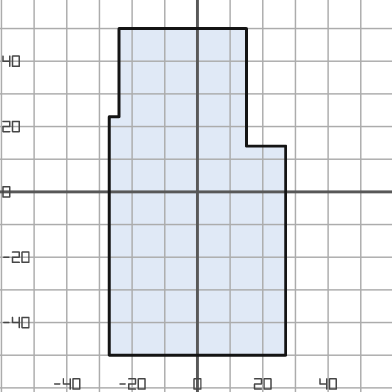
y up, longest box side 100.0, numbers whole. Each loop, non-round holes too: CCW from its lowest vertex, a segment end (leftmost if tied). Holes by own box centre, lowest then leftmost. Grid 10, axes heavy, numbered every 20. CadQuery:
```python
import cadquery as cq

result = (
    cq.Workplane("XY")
    .moveTo(-27.0, -50.0)
    .lineTo(27.0, -50.0)
    .lineTo(27.0, 14.0)
    .lineTo(15.0, 14.0)
    .lineTo(15.0, 50.0)
    .lineTo(-24.0, 50.0)
    .lineTo(-24.0, 23.0)
    .lineTo(-27.0, 23.0)
    .close()
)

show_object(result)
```